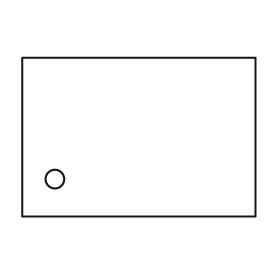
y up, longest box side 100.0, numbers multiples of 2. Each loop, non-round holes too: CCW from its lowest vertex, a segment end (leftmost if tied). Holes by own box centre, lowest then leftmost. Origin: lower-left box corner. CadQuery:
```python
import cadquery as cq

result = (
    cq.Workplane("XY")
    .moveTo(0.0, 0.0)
    .lineTo(100.0, 0.0)
    .lineTo(100.0, 68.0)
    .lineTo(0.0, 68.0)
    .close()
    .moveTo(14.0, 16.0)
    .circle(4.0)
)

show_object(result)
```